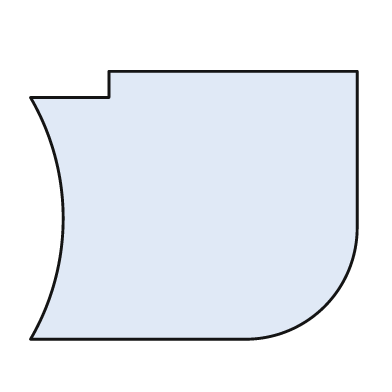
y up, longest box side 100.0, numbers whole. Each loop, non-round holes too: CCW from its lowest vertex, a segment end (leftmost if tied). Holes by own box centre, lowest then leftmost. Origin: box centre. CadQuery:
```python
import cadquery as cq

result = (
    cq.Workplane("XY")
    .moveTo(-50.0, -41.0)
    .lineTo(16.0, -41.0)
    .threePointArc((40.0, -31.0), (50.0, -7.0))
    .lineTo(50.0, 41.0)
    .lineTo(-26.0, 41.0)
    .lineTo(-26.0, 33.0)
    .lineTo(-50.0, 33.0)
    .threePointArc((-40.0, -4.0), (-50.0, -41.0))
    .close()
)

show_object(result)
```